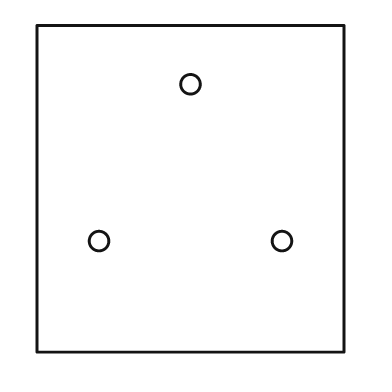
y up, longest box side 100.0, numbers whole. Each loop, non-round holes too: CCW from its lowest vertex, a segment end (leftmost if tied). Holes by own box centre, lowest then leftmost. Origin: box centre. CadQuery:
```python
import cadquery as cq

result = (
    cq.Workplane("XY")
    .moveTo(-47.0, -50.0)
    .lineTo(47.0, -50.0)
    .lineTo(47.0, 50.0)
    .lineTo(-47.0, 50.0)
    .close()
    .moveTo(-28.0, -16.0)
    .circle(3.0)
    .moveTo(28.0, -16.0)
    .circle(3.0)
    .moveTo(0.0, 32.0)
    .circle(3.0)
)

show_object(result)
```